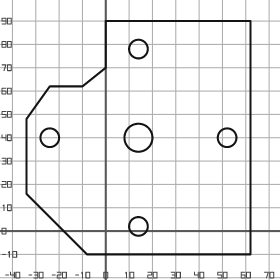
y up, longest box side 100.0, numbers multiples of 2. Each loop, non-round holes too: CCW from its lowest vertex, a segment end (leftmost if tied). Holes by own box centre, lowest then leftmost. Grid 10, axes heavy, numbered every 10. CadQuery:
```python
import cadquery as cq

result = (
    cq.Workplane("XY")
    .moveTo(-8.0, -10.0)
    .lineTo(62.0, -10.0)
    .lineTo(62.0, 90.0)
    .lineTo(0.0, 90.0)
    .lineTo(0.0, 70.0)
    .lineTo(-10.0, 62.0)
    .lineTo(-24.0, 62.0)
    .lineTo(-34.0, 48.0)
    .lineTo(-34.0, 16.0)
    .close()
    .moveTo(14.0, 2.0)
    .circle(4.0)
    .moveTo(-24.0, 40.0)
    .circle(4.0)
    .moveTo(14.0, 40.0)
    .circle(6.0)
    .moveTo(52.0, 40.0)
    .circle(4.0)
    .moveTo(14.0, 78.0)
    .circle(4.0)
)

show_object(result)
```